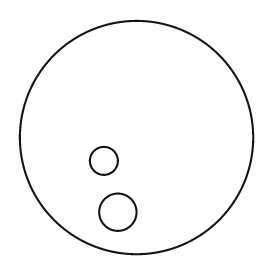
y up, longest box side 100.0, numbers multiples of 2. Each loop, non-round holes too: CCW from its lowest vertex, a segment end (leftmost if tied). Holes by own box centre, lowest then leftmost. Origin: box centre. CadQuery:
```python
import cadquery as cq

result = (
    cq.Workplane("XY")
    .moveTo(0.0, 0.0)
    .circle(50.0)
    .moveTo(-8.0, -32.0)
    .circle(8.0)
    .moveTo(-14.0, -10.0)
    .circle(6.0)
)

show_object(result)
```